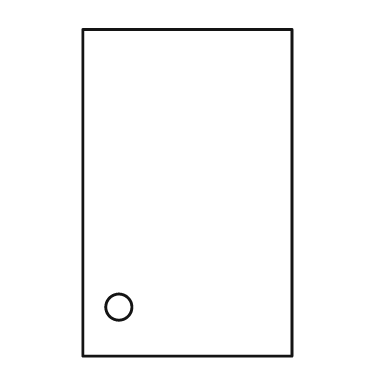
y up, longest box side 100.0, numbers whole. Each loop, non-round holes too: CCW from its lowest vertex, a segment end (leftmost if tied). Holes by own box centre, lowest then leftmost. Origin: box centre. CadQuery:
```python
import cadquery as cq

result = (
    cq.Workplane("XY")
    .moveTo(-32.0, -50.0)
    .lineTo(32.0, -50.0)
    .lineTo(32.0, 50.0)
    .lineTo(-32.0, 50.0)
    .close()
    .moveTo(-21.0, -35.0)
    .circle(4.0)
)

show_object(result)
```